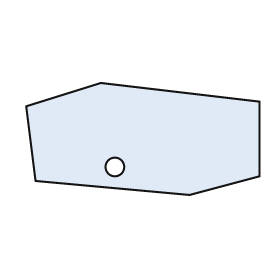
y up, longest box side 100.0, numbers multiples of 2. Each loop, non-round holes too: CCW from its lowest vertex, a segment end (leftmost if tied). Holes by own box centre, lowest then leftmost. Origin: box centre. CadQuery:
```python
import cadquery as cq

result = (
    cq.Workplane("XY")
    .moveTo(20.0, -24.0)
    .lineTo(50.0, -16.0)
    .lineTo(50.0, 16.0)
    .lineTo(-18.0, 24.0)
    .lineTo(-50.0, 14.0)
    .lineTo(-46.0, -18.0)
    .close()
    .moveTo(-12.0, -12.0)
    .circle(4.0)
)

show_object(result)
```